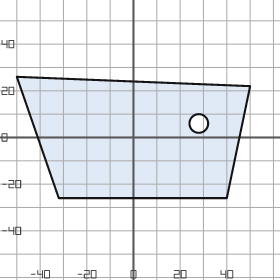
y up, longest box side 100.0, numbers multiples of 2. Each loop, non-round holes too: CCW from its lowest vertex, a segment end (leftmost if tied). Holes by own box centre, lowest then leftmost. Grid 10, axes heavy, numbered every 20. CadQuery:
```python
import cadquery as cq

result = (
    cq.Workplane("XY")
    .moveTo(-32.0, -26.0)
    .lineTo(40.0, -26.0)
    .lineTo(50.0, 22.0)
    .lineTo(-50.0, 26.0)
    .close()
    .moveTo(28.0, 6.0)
    .circle(4.0)
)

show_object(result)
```